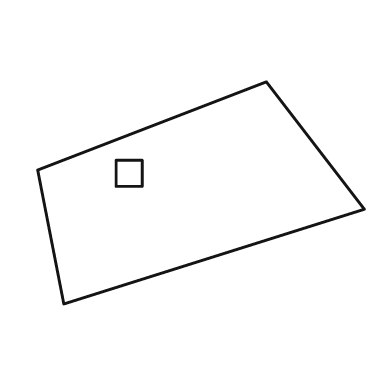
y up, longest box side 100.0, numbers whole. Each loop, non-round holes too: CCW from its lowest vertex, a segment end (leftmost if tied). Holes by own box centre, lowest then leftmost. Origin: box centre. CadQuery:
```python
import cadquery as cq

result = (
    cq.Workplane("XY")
    .moveTo(-42.0, -34.0)
    .lineTo(50.0, -5.0)
    .lineTo(20.0, 34.0)
    .lineTo(-50.0, 7.0)
    .close()
    .moveTo(-26.0, 2.0)
    .lineTo(-18.0, 2.0)
    .lineTo(-18.0, 10.0)
    .lineTo(-26.0, 10.0)
    .close()
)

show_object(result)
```